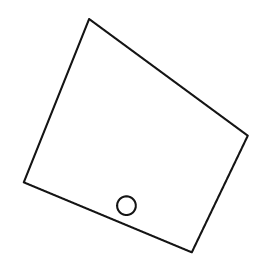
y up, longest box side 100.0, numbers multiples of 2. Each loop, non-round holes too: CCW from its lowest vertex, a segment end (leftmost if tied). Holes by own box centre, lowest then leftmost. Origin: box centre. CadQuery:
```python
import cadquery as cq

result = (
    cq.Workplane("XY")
    .moveTo(24.0, -50.0)
    .lineTo(48.0, 0.0)
    .lineTo(-20.0, 50.0)
    .lineTo(-48.0, -20.0)
    .close()
    .moveTo(-4.0, -30.0)
    .circle(4.0)
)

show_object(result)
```